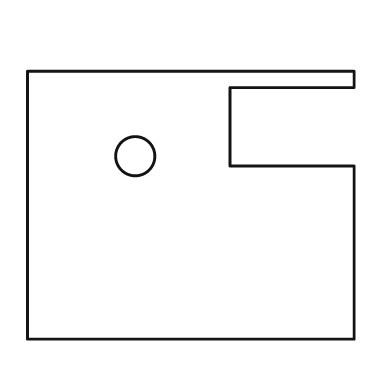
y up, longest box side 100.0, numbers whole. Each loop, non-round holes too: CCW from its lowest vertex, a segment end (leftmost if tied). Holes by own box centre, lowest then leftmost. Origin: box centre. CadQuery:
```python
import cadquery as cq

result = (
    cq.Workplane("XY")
    .moveTo(-50.0, -41.0)
    .lineTo(50.0, -41.0)
    .lineTo(50.0, 12.0)
    .lineTo(12.0, 12.0)
    .lineTo(12.0, 36.0)
    .lineTo(50.0, 36.0)
    .lineTo(50.0, 41.0)
    .lineTo(-50.0, 41.0)
    .close()
    .moveTo(-17.0, 15.0)
    .circle(6.0)
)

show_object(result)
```